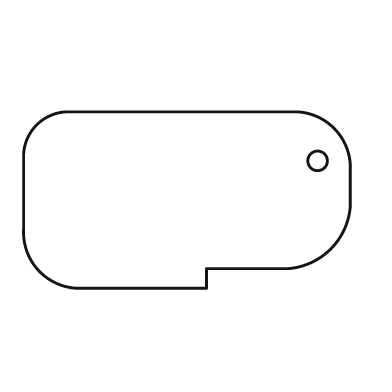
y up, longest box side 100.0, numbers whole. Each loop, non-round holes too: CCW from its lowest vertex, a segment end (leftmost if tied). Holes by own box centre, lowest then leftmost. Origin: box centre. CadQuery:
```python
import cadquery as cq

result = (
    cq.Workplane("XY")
    .moveTo(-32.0, -27.0)
    .lineTo(6.0, -27.0)
    .lineTo(6.0, -21.0)
    .lineTo(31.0, -21.0)
    .threePointArc((44.0, -15.0), (50.0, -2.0))
    .lineTo(50.0, 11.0)
    .threePointArc((45.0, 22.0), (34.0, 27.0))
    .lineTo(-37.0, 27.0)
    .threePointArc((-46.0, 23.0), (-50.0, 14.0))
    .lineTo(-50.0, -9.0)
    .threePointArc((-45.0, -22.0), (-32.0, -27.0))
    .close()
    .moveTo(40.0, 12.0)
    .circle(3.0)
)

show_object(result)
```